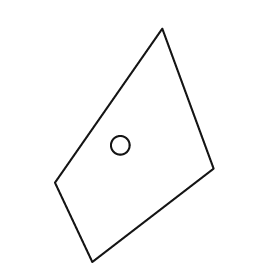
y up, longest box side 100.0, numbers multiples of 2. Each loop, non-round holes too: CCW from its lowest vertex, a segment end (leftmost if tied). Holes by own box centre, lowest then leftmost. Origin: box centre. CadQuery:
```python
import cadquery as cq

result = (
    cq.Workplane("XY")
    .moveTo(-18.0, -50.0)
    .lineTo(34.0, -10.0)
    .lineTo(12.0, 50.0)
    .lineTo(-34.0, -16.0)
    .close()
    .moveTo(-6.0, 0.0)
    .circle(4.0)
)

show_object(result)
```